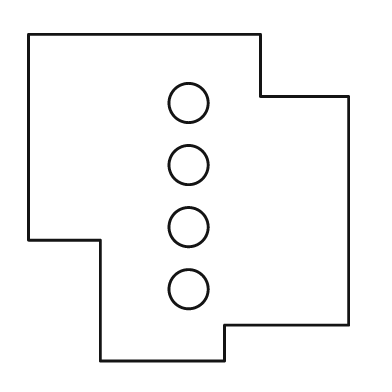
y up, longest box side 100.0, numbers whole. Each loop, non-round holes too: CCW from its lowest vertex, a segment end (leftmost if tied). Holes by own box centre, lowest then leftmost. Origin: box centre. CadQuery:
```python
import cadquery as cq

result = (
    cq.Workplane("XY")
    .moveTo(-27.0, -50.0)
    .lineTo(11.0, -50.0)
    .lineTo(11.0, -39.0)
    .lineTo(49.0, -39.0)
    .lineTo(49.0, 31.0)
    .lineTo(22.0, 31.0)
    .lineTo(22.0, 50.0)
    .lineTo(-49.0, 50.0)
    .lineTo(-49.0, -13.0)
    .lineTo(-27.0, -13.0)
    .close()
    .moveTo(0.0, -28.0)
    .circle(6.0)
    .moveTo(0.0, -9.0)
    .circle(6.0)
    .moveTo(0.0, 10.0)
    .circle(6.0)
    .moveTo(0.0, 29.0)
    .circle(6.0)
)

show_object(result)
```